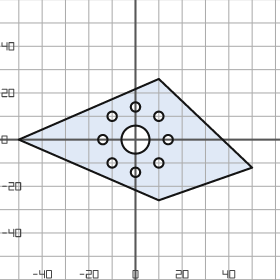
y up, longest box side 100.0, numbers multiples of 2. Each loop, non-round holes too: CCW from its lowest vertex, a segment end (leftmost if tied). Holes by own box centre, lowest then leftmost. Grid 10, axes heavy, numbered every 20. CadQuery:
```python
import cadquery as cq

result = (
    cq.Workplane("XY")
    .moveTo(10.0, -26.0)
    .lineTo(50.0, -12.0)
    .lineTo(10.0, 26.0)
    .lineTo(-50.0, 0.0)
    .close()
    .moveTo(0.0, -14.0)
    .circle(2.0)
    .moveTo(-10.0, -10.0)
    .circle(2.0)
    .moveTo(10.0, -10.0)
    .circle(2.0)
    .moveTo(-14.0, 0.0)
    .circle(2.0)
    .moveTo(0.0, 0.0)
    .circle(6.0)
    .moveTo(14.0, 0.0)
    .circle(2.0)
    .moveTo(-10.0, 10.0)
    .circle(2.0)
    .moveTo(10.0, 10.0)
    .circle(2.0)
    .moveTo(0.0, 14.0)
    .circle(2.0)
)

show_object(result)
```